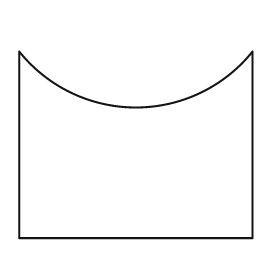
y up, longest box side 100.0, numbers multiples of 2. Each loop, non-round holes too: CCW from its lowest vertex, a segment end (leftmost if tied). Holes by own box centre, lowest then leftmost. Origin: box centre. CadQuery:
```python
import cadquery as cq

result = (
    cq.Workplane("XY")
    .moveTo(-50.0, -40.0)
    .lineTo(50.0, -40.0)
    .lineTo(50.0, 40.0)
    .threePointArc((0.0, 16.0), (-50.0, 40.0))
    .close()
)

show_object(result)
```